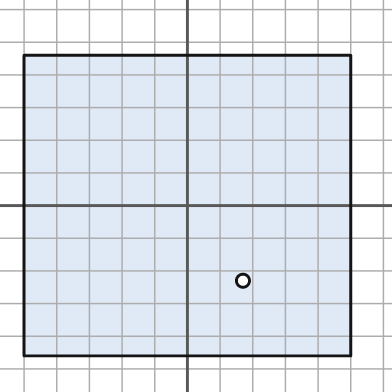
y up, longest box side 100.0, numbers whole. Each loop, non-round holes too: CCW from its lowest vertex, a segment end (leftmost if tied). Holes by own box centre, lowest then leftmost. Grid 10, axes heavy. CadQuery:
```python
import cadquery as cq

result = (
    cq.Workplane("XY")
    .moveTo(-50.0, -46.0)
    .lineTo(50.0, -46.0)
    .lineTo(50.0, 46.0)
    .lineTo(-50.0, 46.0)
    .close()
    .moveTo(17.0, -23.0)
    .circle(2.0)
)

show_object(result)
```